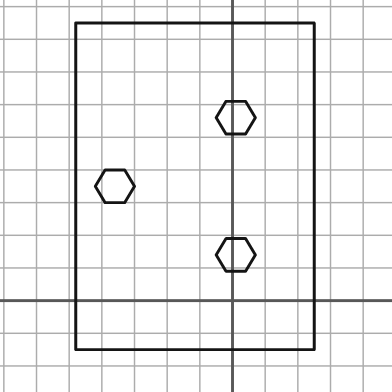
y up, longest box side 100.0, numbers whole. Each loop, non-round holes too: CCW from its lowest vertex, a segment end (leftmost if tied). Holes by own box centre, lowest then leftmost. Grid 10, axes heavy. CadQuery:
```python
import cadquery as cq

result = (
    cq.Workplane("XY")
    .moveTo(-48.0, -15.0)
    .lineTo(25.0, -15.0)
    .lineTo(25.0, 85.0)
    .lineTo(-48.0, 85.0)
    .close()
    .moveTo(-2.0, 9.0)
    .lineTo(4.0, 9.0)
    .lineTo(7.0, 14.0)
    .lineTo(4.0, 19.0)
    .lineTo(-2.0, 19.0)
    .lineTo(-5.0, 14.0)
    .close()
    .moveTo(-39.0, 30.0)
    .lineTo(-33.0, 30.0)
    .lineTo(-30.0, 35.0)
    .lineTo(-33.0, 40.0)
    .lineTo(-39.0, 40.0)
    .lineTo(-42.0, 35.0)
    .close()
    .moveTo(-2.0, 51.0)
    .lineTo(4.0, 51.0)
    .lineTo(7.0, 56.0)
    .lineTo(4.0, 61.0)
    .lineTo(-2.0, 61.0)
    .lineTo(-5.0, 56.0)
    .close()
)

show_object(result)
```